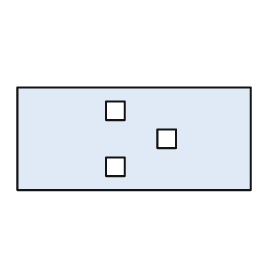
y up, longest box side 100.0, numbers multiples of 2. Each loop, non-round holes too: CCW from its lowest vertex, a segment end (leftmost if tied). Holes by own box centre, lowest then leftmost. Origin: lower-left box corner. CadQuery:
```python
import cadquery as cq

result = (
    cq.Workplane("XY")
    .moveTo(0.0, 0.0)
    .lineTo(100.0, 0.0)
    .lineTo(100.0, 44.0)
    .lineTo(0.0, 44.0)
    .close()
    .moveTo(38.0, 6.0)
    .lineTo(46.0, 6.0)
    .lineTo(46.0, 14.0)
    .lineTo(38.0, 14.0)
    .close()
    .moveTo(60.0, 18.0)
    .lineTo(68.0, 18.0)
    .lineTo(68.0, 26.0)
    .lineTo(60.0, 26.0)
    .close()
    .moveTo(38.0, 30.0)
    .lineTo(46.0, 30.0)
    .lineTo(46.0, 38.0)
    .lineTo(38.0, 38.0)
    .close()
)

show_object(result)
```